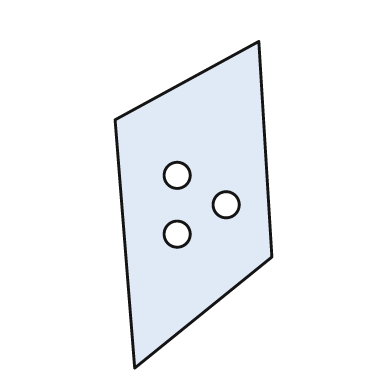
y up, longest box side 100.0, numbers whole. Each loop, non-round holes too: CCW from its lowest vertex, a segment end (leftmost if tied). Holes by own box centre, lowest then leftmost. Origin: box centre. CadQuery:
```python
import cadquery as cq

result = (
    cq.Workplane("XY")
    .moveTo(-18.0, -50.0)
    .lineTo(24.0, -16.0)
    .lineTo(20.0, 50.0)
    .lineTo(-24.0, 26.0)
    .close()
    .moveTo(-5.0, -9.0)
    .circle(4.0)
    .moveTo(10.0, 0.0)
    .circle(4.0)
    .moveTo(-5.0, 9.0)
    .circle(4.0)
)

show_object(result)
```